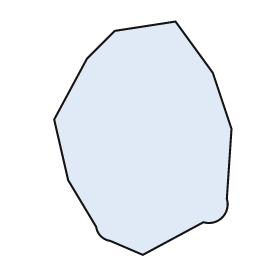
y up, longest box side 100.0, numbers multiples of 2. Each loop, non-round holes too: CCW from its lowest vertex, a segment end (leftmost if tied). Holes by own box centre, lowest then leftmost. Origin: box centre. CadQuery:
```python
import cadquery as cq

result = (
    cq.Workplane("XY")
    .moveTo(0.0, -50.0)
    .lineTo(26.0, -36.0)
    .threePointArc((34.0, -34.0), (36.0, -26.0))
    .lineTo(38.0, 4.0)
    .lineTo(30.0, 28.0)
    .lineTo(14.0, 50.0)
    .lineTo(-12.0, 46.0)
    .lineTo(-24.0, 34.0)
    .lineTo(-38.0, 8.0)
    .lineTo(-32.0, -18.0)
    .lineTo(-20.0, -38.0)
    .threePointArc((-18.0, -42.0), (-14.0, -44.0))
    .close()
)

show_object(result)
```